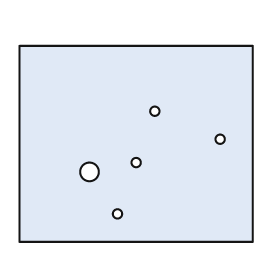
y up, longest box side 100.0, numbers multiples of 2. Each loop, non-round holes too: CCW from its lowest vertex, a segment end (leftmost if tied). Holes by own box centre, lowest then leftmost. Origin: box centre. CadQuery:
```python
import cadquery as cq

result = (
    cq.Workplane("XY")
    .moveTo(-50.0, -42.0)
    .lineTo(50.0, -42.0)
    .lineTo(50.0, 42.0)
    .lineTo(-50.0, 42.0)
    .close()
    .moveTo(-8.0, -30.0)
    .circle(2.0)
    .moveTo(-20.0, -12.0)
    .circle(4.0)
    .moveTo(0.0, -8.0)
    .circle(2.0)
    .moveTo(36.0, 2.0)
    .circle(2.0)
    .moveTo(8.0, 14.0)
    .circle(2.0)
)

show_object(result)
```